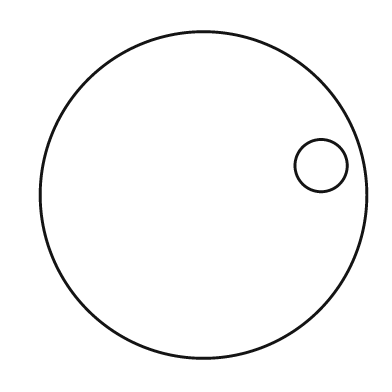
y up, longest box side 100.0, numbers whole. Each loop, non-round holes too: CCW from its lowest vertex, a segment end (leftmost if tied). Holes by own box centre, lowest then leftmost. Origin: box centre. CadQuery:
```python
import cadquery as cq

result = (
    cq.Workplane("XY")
    .moveTo(0.0, 0.0)
    .circle(50.0)
    .moveTo(36.0, 9.0)
    .circle(8.0)
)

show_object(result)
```